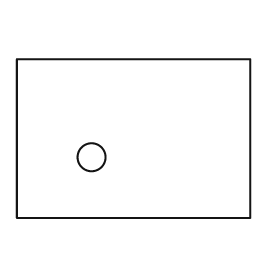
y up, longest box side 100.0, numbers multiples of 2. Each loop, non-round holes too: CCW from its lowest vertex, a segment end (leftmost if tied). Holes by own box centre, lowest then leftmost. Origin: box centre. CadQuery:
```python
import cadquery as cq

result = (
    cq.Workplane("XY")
    .moveTo(-50.0, -34.0)
    .lineTo(50.0, -34.0)
    .lineTo(50.0, 34.0)
    .lineTo(-50.0, 34.0)
    .close()
    .moveTo(-18.0, -8.0)
    .circle(6.0)
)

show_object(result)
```